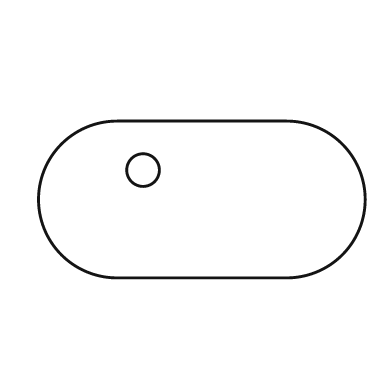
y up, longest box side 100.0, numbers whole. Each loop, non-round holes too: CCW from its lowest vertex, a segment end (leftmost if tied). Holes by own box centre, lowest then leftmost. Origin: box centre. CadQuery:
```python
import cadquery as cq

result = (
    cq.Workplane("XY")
    .moveTo(-26.0, -24.0)
    .lineTo(26.0, -24.0)
    .threePointArc((50.0, 0.0), (26.0, 24.0))
    .lineTo(-26.0, 24.0)
    .threePointArc((-50.0, 0.0), (-26.0, -24.0))
    .close()
    .moveTo(-18.0, 9.0)
    .circle(5.0)
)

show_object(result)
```